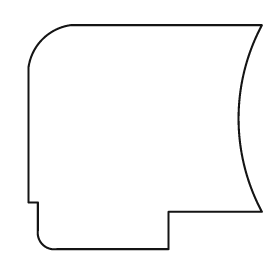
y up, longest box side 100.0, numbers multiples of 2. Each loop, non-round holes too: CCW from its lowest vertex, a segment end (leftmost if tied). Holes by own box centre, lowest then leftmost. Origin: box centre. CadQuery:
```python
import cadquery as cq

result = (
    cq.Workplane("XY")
    .moveTo(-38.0, -48.0)
    .lineTo(10.0, -48.0)
    .lineTo(10.0, -32.0)
    .lineTo(50.0, -32.0)
    .threePointArc((40.0, 8.0), (50.0, 48.0))
    .lineTo(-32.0, 48.0)
    .threePointArc((-44.0, 42.0), (-50.0, 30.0))
    .lineTo(-50.0, -28.0)
    .lineTo(-46.0, -28.0)
    .lineTo(-46.0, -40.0)
    .threePointArc((-44.0, -46.0), (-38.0, -48.0))
    .close()
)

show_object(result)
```